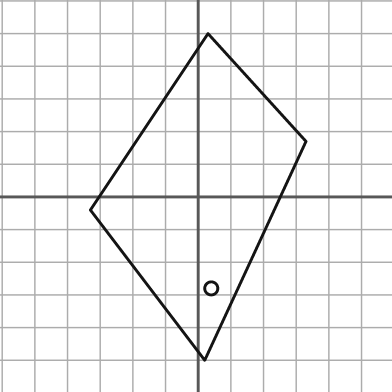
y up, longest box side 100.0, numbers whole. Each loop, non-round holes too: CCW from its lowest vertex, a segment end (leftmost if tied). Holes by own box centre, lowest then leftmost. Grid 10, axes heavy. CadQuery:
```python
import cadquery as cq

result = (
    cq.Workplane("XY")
    .moveTo(2.0, -50.0)
    .lineTo(33.0, 17.0)
    .lineTo(3.0, 50.0)
    .lineTo(-33.0, -4.0)
    .close()
    .moveTo(4.0, -28.0)
    .circle(2.0)
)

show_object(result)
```